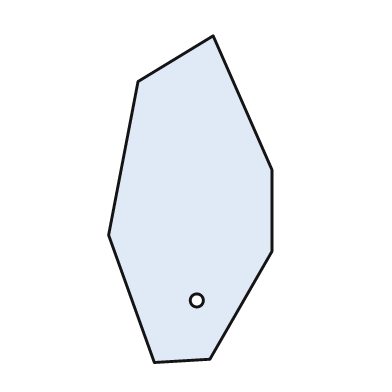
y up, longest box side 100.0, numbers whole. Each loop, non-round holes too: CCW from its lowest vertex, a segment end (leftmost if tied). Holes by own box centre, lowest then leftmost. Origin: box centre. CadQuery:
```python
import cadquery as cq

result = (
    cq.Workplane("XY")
    .moveTo(-11.0, -50.0)
    .lineTo(6.0, -49.0)
    .lineTo(25.0, -16.0)
    .lineTo(25.0, 9.0)
    .lineTo(7.0, 50.0)
    .lineTo(-16.0, 36.0)
    .lineTo(-25.0, -11.0)
    .close()
    .moveTo(2.0, -31.0)
    .circle(2.0)
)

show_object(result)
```